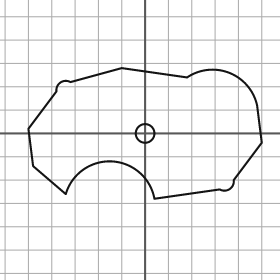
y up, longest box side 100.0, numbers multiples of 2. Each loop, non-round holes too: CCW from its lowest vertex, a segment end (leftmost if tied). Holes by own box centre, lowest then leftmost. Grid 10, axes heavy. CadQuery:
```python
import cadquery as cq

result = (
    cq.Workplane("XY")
    .moveTo(4.0, -28.0)
    .lineTo(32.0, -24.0)
    .threePointArc((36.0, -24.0), (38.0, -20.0))
    .lineTo(50.0, -4.0)
    .lineTo(48.0, 12.0)
    .threePointArc((36.0, 26.0), (18.0, 24.0))
    .lineTo(-10.0, 28.0)
    .lineTo(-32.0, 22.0)
    .threePointArc((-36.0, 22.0), (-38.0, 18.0))
    .lineTo(-50.0, 2.0)
    .lineTo(-48.0, -14.0)
    .lineTo(-34.0, -26.0)
    .threePointArc((-14.0, -12.0), (4.0, -28.0))
    .close()
    .moveTo(0.0, 0.0)
    .circle(4.0)
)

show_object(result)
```